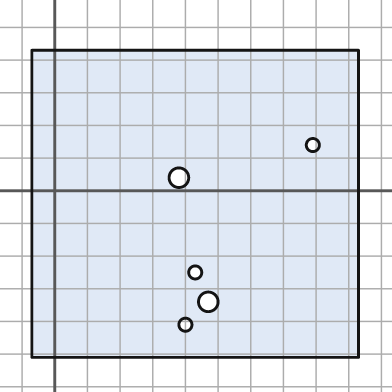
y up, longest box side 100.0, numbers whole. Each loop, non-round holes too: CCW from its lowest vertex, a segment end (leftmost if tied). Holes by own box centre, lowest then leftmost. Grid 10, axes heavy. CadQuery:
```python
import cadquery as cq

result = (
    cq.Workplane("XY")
    .moveTo(-7.0, -51.0)
    .lineTo(93.0, -51.0)
    .lineTo(93.0, 43.0)
    .lineTo(-7.0, 43.0)
    .close()
    .moveTo(40.0, -41.0)
    .circle(2.0)
    .moveTo(47.0, -34.0)
    .circle(3.0)
    .moveTo(43.0, -25.0)
    .circle(2.0)
    .moveTo(38.0, 4.0)
    .circle(3.0)
    .moveTo(79.0, 14.0)
    .circle(2.0)
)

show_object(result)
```